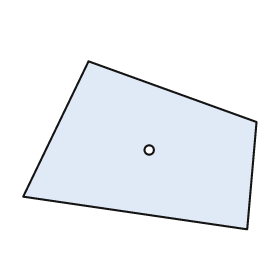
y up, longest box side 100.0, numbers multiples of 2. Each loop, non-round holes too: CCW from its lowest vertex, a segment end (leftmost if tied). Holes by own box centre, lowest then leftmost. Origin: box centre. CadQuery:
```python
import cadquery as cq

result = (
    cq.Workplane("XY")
    .moveTo(46.0, -36.0)
    .lineTo(50.0, 10.0)
    .lineTo(-22.0, 36.0)
    .lineTo(-50.0, -22.0)
    .close()
    .moveTo(4.0, -2.0)
    .circle(2.0)
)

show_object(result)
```